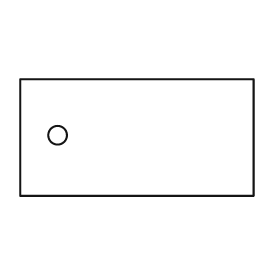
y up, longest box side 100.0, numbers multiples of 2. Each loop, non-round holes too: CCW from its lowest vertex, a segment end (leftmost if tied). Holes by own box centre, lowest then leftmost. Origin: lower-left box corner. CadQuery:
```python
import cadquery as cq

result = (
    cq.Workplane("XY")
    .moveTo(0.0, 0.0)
    .lineTo(100.0, 0.0)
    .lineTo(100.0, 50.0)
    .lineTo(0.0, 50.0)
    .close()
    .moveTo(16.0, 26.0)
    .circle(4.0)
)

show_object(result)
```